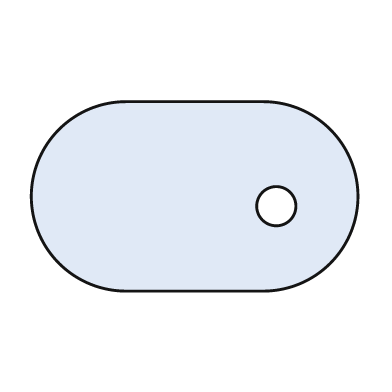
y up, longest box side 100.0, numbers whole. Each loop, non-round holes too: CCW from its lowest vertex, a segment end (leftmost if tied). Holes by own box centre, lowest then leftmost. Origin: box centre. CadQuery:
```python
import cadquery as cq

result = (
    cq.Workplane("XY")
    .moveTo(-21.0, -29.0)
    .lineTo(21.0, -29.0)
    .threePointArc((50.0, 0.0), (21.0, 29.0))
    .lineTo(-21.0, 29.0)
    .threePointArc((-50.0, 0.0), (-21.0, -29.0))
    .close()
    .moveTo(25.0, -3.0)
    .circle(6.0)
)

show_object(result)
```